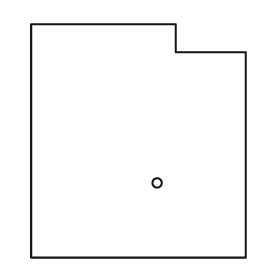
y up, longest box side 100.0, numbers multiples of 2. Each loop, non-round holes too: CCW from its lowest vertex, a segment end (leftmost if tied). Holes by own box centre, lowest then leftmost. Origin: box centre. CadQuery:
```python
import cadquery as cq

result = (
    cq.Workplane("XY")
    .moveTo(-46.0, -50.0)
    .lineTo(46.0, -50.0)
    .lineTo(46.0, 38.0)
    .lineTo(16.0, 38.0)
    .lineTo(16.0, 50.0)
    .lineTo(-46.0, 50.0)
    .close()
    .moveTo(8.0, -18.0)
    .circle(2.0)
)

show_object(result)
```